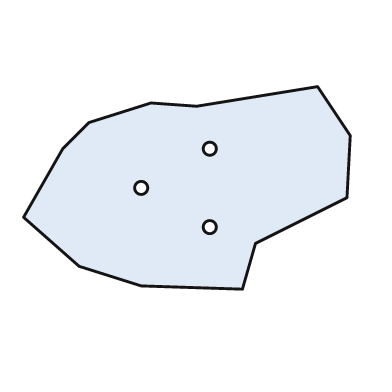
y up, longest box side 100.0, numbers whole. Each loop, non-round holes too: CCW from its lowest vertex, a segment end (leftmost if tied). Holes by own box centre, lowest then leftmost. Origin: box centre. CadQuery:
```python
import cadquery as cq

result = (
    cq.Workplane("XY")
    .moveTo(17.0, -31.0)
    .lineTo(21.0, -17.0)
    .lineTo(49.0, -3.0)
    .lineTo(50.0, 16.0)
    .lineTo(40.0, 31.0)
    .lineTo(3.0, 25.0)
    .lineTo(-11.0, 26.0)
    .lineTo(-30.0, 20.0)
    .lineTo(-38.0, 12.0)
    .lineTo(-50.0, -9.0)
    .lineTo(-33.0, -24.0)
    .lineTo(-14.0, -30.0)
    .close()
    .moveTo(7.0, -12.0)
    .circle(2.0)
    .moveTo(-14.0, 0.0)
    .circle(2.0)
    .moveTo(7.0, 12.0)
    .circle(2.0)
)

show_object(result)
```